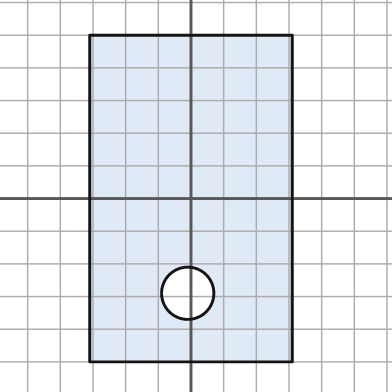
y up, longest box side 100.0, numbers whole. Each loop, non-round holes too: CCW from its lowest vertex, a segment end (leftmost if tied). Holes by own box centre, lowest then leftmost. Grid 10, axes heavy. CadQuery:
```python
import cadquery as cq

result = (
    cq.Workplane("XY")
    .moveTo(-31.0, -50.0)
    .lineTo(31.0, -50.0)
    .lineTo(31.0, 50.0)
    .lineTo(-31.0, 50.0)
    .close()
    .moveTo(-1.0, -29.0)
    .circle(8.0)
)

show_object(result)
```